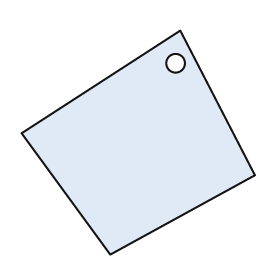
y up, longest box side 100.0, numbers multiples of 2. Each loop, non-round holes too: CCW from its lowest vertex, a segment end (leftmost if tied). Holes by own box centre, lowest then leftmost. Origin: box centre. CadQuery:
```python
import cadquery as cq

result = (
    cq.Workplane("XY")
    .moveTo(-12.0, -48.0)
    .lineTo(50.0, -14.0)
    .lineTo(18.0, 48.0)
    .lineTo(-50.0, 4.0)
    .close()
    .moveTo(16.0, 34.0)
    .circle(4.0)
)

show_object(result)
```